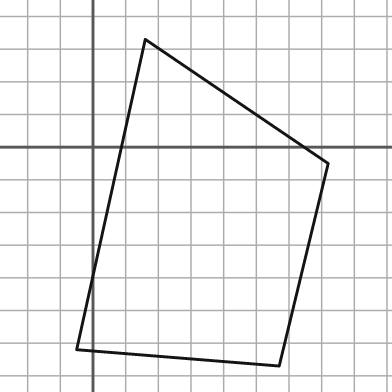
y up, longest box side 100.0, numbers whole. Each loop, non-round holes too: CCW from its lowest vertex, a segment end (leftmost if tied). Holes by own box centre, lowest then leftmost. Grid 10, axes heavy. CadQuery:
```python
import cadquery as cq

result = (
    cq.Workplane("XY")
    .moveTo(57.0, -67.0)
    .lineTo(72.0, -5.0)
    .lineTo(16.0, 33.0)
    .lineTo(-5.0, -62.0)
    .close()
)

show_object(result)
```